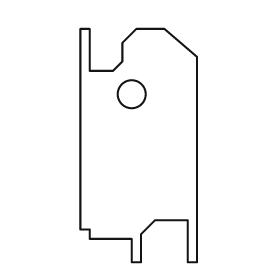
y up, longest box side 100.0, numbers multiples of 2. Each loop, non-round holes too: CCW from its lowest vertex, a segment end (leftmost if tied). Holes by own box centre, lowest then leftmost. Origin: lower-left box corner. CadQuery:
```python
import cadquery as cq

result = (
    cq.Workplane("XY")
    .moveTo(22.0, 0.0)
    .lineTo(26.0, 0.0)
    .lineTo(26.0, 12.0)
    .lineTo(32.0, 18.0)
    .lineTo(46.0, 18.0)
    .lineTo(46.0, 0.0)
    .lineTo(50.0, 0.0)
    .lineTo(50.0, 88.0)
    .lineTo(36.0, 100.0)
    .lineTo(24.0, 100.0)
    .lineTo(18.0, 94.0)
    .lineTo(18.0, 86.0)
    .lineTo(14.0, 82.0)
    .lineTo(4.0, 82.0)
    .lineTo(4.0, 100.0)
    .lineTo(0.0, 100.0)
    .lineTo(0.0, 14.0)
    .lineTo(4.0, 14.0)
    .lineTo(4.0, 10.0)
    .lineTo(22.0, 10.0)
    .close()
    .moveTo(22.0, 72.0)
    .circle(6.0)
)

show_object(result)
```